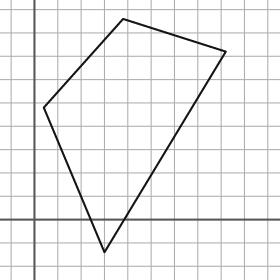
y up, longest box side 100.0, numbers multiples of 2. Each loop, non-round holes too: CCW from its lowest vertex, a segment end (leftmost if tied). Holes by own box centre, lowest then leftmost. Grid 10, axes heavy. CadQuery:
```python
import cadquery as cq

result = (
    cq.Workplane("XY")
    .moveTo(30.0, -14.0)
    .lineTo(82.0, 72.0)
    .lineTo(38.0, 86.0)
    .lineTo(4.0, 48.0)
    .close()
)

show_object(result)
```